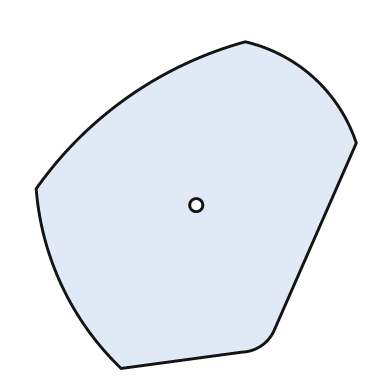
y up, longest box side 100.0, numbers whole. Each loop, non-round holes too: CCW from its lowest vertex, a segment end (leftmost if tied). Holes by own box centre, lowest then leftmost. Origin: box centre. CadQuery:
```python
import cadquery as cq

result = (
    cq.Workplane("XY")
    .moveTo(-23.0, -50.0)
    .lineTo(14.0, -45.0)
    .threePointArc((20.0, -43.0), (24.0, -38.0))
    .lineTo(49.0, 19.0)
    .threePointArc((36.0, 39.0), (15.0, 50.0))
    .threePointArc((-21.0, 33.0), (-49.0, 5.0))
    .threePointArc((-41.0, -25.0), (-23.0, -50.0))
    .close()
    .moveTo(0.0, 0.0)
    .circle(2.0)
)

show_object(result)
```